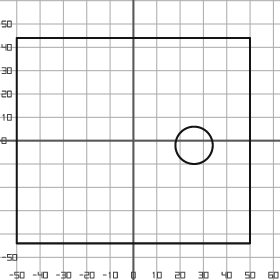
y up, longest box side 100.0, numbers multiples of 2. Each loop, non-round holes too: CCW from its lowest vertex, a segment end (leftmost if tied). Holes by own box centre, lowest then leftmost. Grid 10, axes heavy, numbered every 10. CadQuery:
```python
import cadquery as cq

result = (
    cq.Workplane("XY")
    .moveTo(-50.0, -44.0)
    .lineTo(50.0, -44.0)
    .lineTo(50.0, 44.0)
    .lineTo(-50.0, 44.0)
    .close()
    .moveTo(26.0, -2.0)
    .circle(8.0)
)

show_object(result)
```